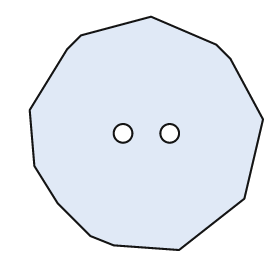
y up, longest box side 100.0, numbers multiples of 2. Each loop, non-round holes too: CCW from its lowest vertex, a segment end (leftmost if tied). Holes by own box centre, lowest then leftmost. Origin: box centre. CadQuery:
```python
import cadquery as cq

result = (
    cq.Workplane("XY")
    .moveTo(14.0, -50.0)
    .lineTo(42.0, -28.0)
    .lineTo(50.0, 6.0)
    .lineTo(36.0, 32.0)
    .lineTo(30.0, 38.0)
    .lineTo(2.0, 50.0)
    .lineTo(-28.0, 42.0)
    .lineTo(-34.0, 36.0)
    .lineTo(-50.0, 10.0)
    .lineTo(-48.0, -14.0)
    .lineTo(-38.0, -30.0)
    .lineTo(-24.0, -44.0)
    .lineTo(-14.0, -48.0)
    .close()
    .moveTo(-10.0, 0.0)
    .circle(4.0)
    .moveTo(10.0, 0.0)
    .circle(4.0)
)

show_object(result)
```